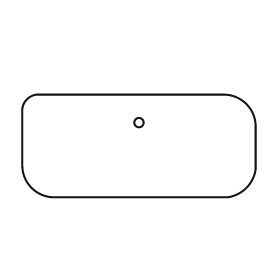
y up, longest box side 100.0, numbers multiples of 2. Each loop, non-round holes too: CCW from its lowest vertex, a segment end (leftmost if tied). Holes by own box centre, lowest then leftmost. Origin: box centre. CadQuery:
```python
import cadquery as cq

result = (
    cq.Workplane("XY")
    .moveTo(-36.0, -22.0)
    .lineTo(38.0, -22.0)
    .threePointArc((46.0, -18.0), (50.0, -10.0))
    .lineTo(50.0, 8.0)
    .threePointArc((46.0, 18.0), (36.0, 22.0))
    .lineTo(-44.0, 22.0)
    .threePointArc((-48.0, 20.0), (-50.0, 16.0))
    .lineTo(-50.0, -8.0)
    .threePointArc((-46.0, -18.0), (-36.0, -22.0))
    .close()
    .moveTo(0.0, 10.0)
    .circle(2.0)
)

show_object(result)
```